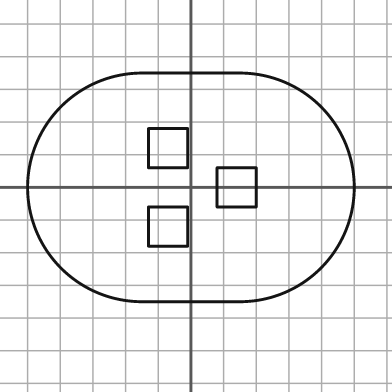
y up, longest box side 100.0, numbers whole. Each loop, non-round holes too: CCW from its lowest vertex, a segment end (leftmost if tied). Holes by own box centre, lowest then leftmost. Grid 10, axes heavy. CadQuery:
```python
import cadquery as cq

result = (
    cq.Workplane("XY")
    .moveTo(-15.0, -35.0)
    .lineTo(15.0, -35.0)
    .threePointArc((50.0, 0.0), (15.0, 35.0))
    .lineTo(-15.0, 35.0)
    .threePointArc((-50.0, 0.0), (-15.0, -35.0))
    .close()
    .moveTo(-13.0, -18.0)
    .lineTo(-1.0, -18.0)
    .lineTo(-1.0, -6.0)
    .lineTo(-13.0, -6.0)
    .close()
    .moveTo(8.0, -6.0)
    .lineTo(20.0, -6.0)
    .lineTo(20.0, 6.0)
    .lineTo(8.0, 6.0)
    .close()
    .moveTo(-13.0, 6.0)
    .lineTo(-1.0, 6.0)
    .lineTo(-1.0, 18.0)
    .lineTo(-13.0, 18.0)
    .close()
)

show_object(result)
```